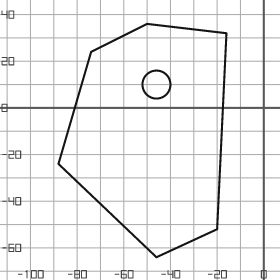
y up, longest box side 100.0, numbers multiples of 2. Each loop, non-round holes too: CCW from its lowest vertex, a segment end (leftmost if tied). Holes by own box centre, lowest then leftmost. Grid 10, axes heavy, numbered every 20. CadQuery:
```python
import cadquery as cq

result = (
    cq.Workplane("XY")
    .moveTo(-46.0, -64.0)
    .lineTo(-20.0, -52.0)
    .lineTo(-16.0, 32.0)
    .lineTo(-50.0, 36.0)
    .lineTo(-74.0, 24.0)
    .lineTo(-88.0, -24.0)
    .close()
    .moveTo(-46.0, 10.0)
    .circle(6.0)
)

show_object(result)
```